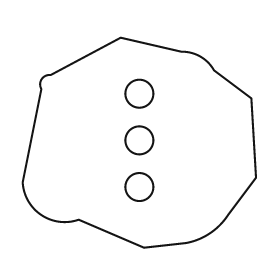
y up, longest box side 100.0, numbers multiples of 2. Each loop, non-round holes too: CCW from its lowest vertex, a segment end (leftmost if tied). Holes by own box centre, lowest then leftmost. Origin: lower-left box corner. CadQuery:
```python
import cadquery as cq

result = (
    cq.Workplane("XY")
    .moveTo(52.0, 0.0)
    .lineTo(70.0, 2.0)
    .threePointArc((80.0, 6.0), (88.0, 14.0))
    .lineTo(100.0, 30.0)
    .lineTo(98.0, 64.0)
    .lineTo(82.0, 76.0)
    .threePointArc((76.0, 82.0), (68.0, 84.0))
    .lineTo(42.0, 90.0)
    .lineTo(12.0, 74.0)
    .threePointArc((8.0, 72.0), (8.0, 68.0))
    .lineTo(0.0, 28.0)
    .threePointArc((8.0, 14.0), (24.0, 12.0))
    .close()
    .moveTo(50.0, 26.0)
    .circle(6.0)
    .moveTo(50.0, 46.0)
    .circle(6.0)
    .moveTo(50.0, 66.0)
    .circle(6.0)
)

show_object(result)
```